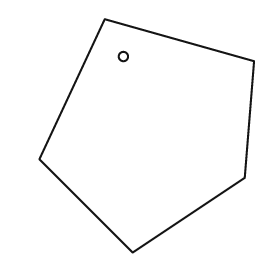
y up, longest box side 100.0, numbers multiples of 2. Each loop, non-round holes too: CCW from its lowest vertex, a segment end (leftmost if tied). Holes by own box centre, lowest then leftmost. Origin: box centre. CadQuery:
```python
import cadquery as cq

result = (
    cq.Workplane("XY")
    .moveTo(-6.0, -50.0)
    .lineTo(42.0, -18.0)
    .lineTo(46.0, 32.0)
    .lineTo(-18.0, 50.0)
    .lineTo(-46.0, -10.0)
    .close()
    .moveTo(-10.0, 34.0)
    .circle(2.0)
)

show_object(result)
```